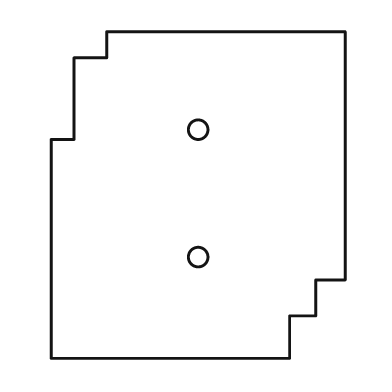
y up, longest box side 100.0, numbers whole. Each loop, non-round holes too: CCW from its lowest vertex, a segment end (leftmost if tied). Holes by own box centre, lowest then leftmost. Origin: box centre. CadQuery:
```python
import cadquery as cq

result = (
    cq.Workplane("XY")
    .moveTo(-45.0, -50.0)
    .lineTo(28.0, -50.0)
    .lineTo(28.0, -37.0)
    .lineTo(36.0, -37.0)
    .lineTo(36.0, -26.0)
    .lineTo(45.0, -26.0)
    .lineTo(45.0, 50.0)
    .lineTo(-28.0, 50.0)
    .lineTo(-28.0, 42.0)
    .lineTo(-38.0, 42.0)
    .lineTo(-38.0, 17.0)
    .lineTo(-45.0, 17.0)
    .close()
    .moveTo(0.0, -19.0)
    .circle(3.0)
    .moveTo(0.0, 20.0)
    .circle(3.0)
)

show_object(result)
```